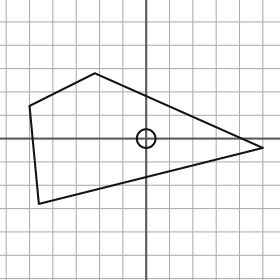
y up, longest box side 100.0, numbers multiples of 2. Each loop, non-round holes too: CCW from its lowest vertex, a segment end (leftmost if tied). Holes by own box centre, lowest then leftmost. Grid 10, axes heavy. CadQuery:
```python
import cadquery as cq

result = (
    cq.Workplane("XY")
    .moveTo(-46.0, -28.0)
    .lineTo(50.0, -4.0)
    .lineTo(-22.0, 28.0)
    .lineTo(-50.0, 14.0)
    .close()
    .moveTo(0.0, 0.0)
    .circle(4.0)
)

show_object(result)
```